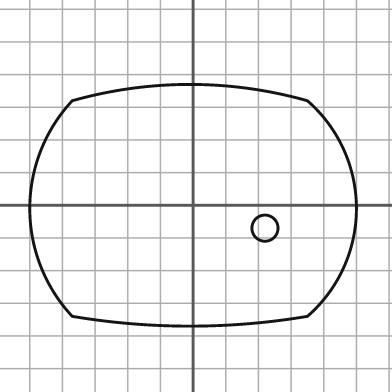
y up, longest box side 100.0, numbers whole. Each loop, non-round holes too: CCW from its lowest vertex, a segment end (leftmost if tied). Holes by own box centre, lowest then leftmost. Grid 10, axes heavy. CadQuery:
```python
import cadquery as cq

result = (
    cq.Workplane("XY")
    .moveTo(-37.0, -34.0)
    .threePointArc((-1.0, -37.0), (35.0, -34.0))
    .threePointArc((50.0, -1.0), (35.0, 32.0))
    .threePointArc((-1.0, 37.0), (-37.0, 32.0))
    .threePointArc((-50.0, -1.0), (-37.0, -34.0))
    .close()
    .moveTo(22.0, -7.0)
    .circle(4.0)
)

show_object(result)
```